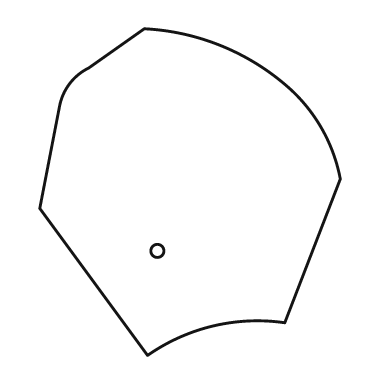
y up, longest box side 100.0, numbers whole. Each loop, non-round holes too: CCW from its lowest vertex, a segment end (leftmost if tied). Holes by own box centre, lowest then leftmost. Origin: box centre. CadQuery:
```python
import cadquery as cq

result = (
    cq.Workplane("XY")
    .moveTo(-13.0, -50.0)
    .threePointArc((7.0, -41.0), (29.0, -40.0))
    .lineTo(46.0, 4.0)
    .threePointArc((40.0, 20.0), (29.0, 33.0))
    .threePointArc((9.0, 45.0), (-14.0, 50.0))
    .lineTo(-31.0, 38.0)
    .threePointArc((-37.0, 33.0), (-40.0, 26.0))
    .lineTo(-46.0, -5.0)
    .close()
    .moveTo(-10.0, -18.0)
    .circle(2.0)
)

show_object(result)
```